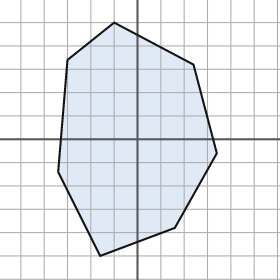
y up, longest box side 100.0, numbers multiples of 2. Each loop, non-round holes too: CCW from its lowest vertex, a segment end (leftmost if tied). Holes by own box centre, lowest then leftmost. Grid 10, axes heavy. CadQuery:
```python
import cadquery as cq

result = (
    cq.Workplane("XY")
    .moveTo(-16.0, -50.0)
    .lineTo(16.0, -38.0)
    .lineTo(34.0, -6.0)
    .lineTo(24.0, 32.0)
    .lineTo(-10.0, 50.0)
    .lineTo(-30.0, 34.0)
    .lineTo(-34.0, -14.0)
    .close()
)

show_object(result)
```